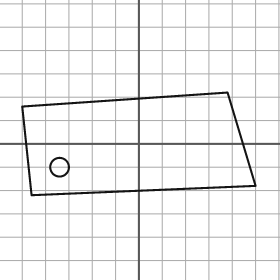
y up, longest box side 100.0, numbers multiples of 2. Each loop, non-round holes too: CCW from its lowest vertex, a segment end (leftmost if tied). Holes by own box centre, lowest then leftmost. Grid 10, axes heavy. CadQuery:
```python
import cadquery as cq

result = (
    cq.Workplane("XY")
    .moveTo(-46.0, -22.0)
    .lineTo(50.0, -18.0)
    .lineTo(38.0, 22.0)
    .lineTo(-50.0, 16.0)
    .close()
    .moveTo(-34.0, -10.0)
    .circle(4.0)
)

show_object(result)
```